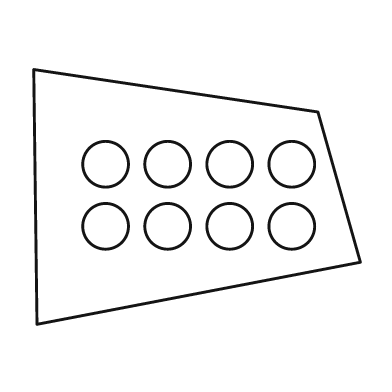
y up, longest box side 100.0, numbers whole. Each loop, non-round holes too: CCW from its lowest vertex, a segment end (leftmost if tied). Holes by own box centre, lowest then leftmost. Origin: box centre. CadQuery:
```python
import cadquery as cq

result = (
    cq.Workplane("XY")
    .moveTo(-49.0, -39.0)
    .lineTo(50.0, -20.0)
    .lineTo(37.0, 26.0)
    .lineTo(-50.0, 39.0)
    .close()
    .moveTo(-28.0, -9.0)
    .circle(7.0)
    .moveTo(-9.0, -9.0)
    .circle(7.0)
    .moveTo(10.0, -9.0)
    .circle(7.0)
    .moveTo(29.0, -9.0)
    .circle(7.0)
    .moveTo(-28.0, 10.0)
    .circle(7.0)
    .moveTo(-9.0, 10.0)
    .circle(7.0)
    .moveTo(10.0, 10.0)
    .circle(7.0)
    .moveTo(29.0, 10.0)
    .circle(7.0)
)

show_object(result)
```